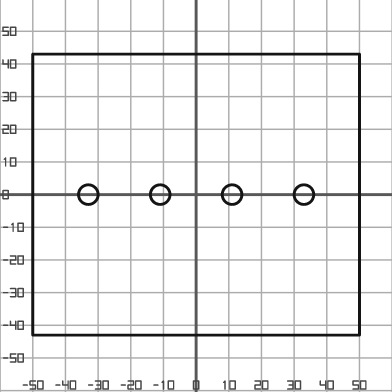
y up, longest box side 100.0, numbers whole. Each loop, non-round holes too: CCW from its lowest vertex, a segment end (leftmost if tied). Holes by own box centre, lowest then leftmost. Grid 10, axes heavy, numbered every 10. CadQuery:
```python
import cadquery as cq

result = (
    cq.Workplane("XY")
    .moveTo(-50.0, -43.0)
    .lineTo(50.0, -43.0)
    .lineTo(50.0, 43.0)
    .lineTo(-50.0, 43.0)
    .close()
    .moveTo(-33.0, 0.0)
    .circle(3.0)
    .moveTo(-11.0, 0.0)
    .circle(3.0)
    .moveTo(11.0, 0.0)
    .circle(3.0)
    .moveTo(33.0, 0.0)
    .circle(3.0)
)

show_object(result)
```